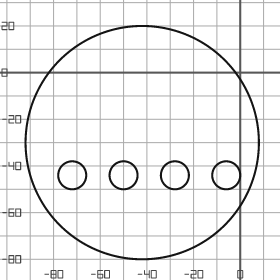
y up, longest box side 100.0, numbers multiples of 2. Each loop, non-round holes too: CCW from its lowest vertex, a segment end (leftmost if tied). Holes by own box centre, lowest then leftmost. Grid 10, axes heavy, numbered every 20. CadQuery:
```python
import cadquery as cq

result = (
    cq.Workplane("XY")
    .moveTo(-42.0, -30.0)
    .circle(50.0)
    .moveTo(-72.0, -44.0)
    .circle(6.0)
    .moveTo(-50.0, -44.0)
    .circle(6.0)
    .moveTo(-28.0, -44.0)
    .circle(6.0)
    .moveTo(-6.0, -44.0)
    .circle(6.0)
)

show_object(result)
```